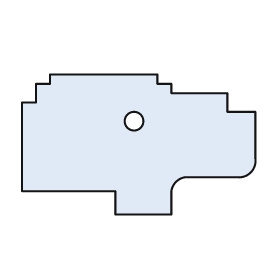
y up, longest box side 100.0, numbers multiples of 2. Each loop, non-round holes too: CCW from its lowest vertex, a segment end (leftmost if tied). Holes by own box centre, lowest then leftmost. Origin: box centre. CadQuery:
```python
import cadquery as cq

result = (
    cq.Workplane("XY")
    .moveTo(-10.0, -30.0)
    .lineTo(14.0, -30.0)
    .lineTo(14.0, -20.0)
    .threePointArc((16.0, -16.0), (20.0, -14.0))
    .lineTo(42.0, -14.0)
    .threePointArc((48.0, -12.0), (50.0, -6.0))
    .lineTo(50.0, 14.0)
    .lineTo(38.0, 14.0)
    .lineTo(38.0, 22.0)
    .lineTo(14.0, 22.0)
    .lineTo(14.0, 26.0)
    .lineTo(8.0, 26.0)
    .lineTo(8.0, 30.0)
    .lineTo(-38.0, 30.0)
    .lineTo(-38.0, 26.0)
    .lineTo(-44.0, 26.0)
    .lineTo(-44.0, 18.0)
    .lineTo(-50.0, 18.0)
    .lineTo(-50.0, -20.0)
    .lineTo(-10.0, -20.0)
    .close()
    .moveTo(-2.0, 10.0)
    .circle(4.0)
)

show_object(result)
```